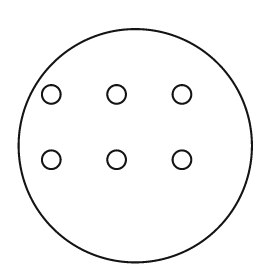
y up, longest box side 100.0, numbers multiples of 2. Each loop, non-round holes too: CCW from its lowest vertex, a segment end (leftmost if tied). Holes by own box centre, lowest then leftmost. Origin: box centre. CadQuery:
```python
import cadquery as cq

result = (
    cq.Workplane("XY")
    .moveTo(0.0, 0.0)
    .circle(50.0)
    .moveTo(-36.0, -6.0)
    .circle(4.0)
    .moveTo(-8.0, -6.0)
    .circle(4.0)
    .moveTo(20.0, -6.0)
    .circle(4.0)
    .moveTo(-36.0, 22.0)
    .circle(4.0)
    .moveTo(-8.0, 22.0)
    .circle(4.0)
    .moveTo(20.0, 22.0)
    .circle(4.0)
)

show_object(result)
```